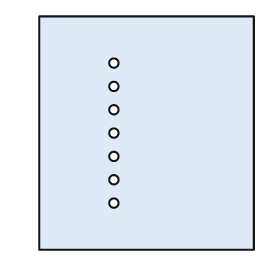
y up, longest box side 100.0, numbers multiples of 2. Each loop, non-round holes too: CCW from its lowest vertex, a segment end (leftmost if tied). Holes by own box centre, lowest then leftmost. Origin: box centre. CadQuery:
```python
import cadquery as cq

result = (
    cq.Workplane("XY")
    .moveTo(-46.0, -50.0)
    .lineTo(46.0, -50.0)
    .lineTo(46.0, 50.0)
    .lineTo(-46.0, 50.0)
    .close()
    .moveTo(-14.0, -30.0)
    .circle(2.0)
    .moveTo(-14.0, -20.0)
    .circle(2.0)
    .moveTo(-14.0, -10.0)
    .circle(2.0)
    .moveTo(-14.0, 0.0)
    .circle(2.0)
    .moveTo(-14.0, 10.0)
    .circle(2.0)
    .moveTo(-14.0, 20.0)
    .circle(2.0)
    .moveTo(-14.0, 30.0)
    .circle(2.0)
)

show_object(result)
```